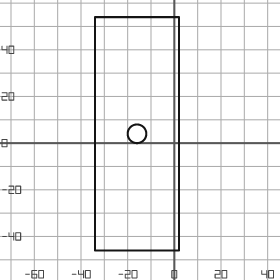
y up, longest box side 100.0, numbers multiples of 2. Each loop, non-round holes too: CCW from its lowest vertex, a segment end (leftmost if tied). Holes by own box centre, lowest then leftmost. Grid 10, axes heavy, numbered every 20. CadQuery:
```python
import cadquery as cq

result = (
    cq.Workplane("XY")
    .moveTo(-34.0, -46.0)
    .lineTo(2.0, -46.0)
    .lineTo(2.0, 54.0)
    .lineTo(-34.0, 54.0)
    .close()
    .moveTo(-16.0, 4.0)
    .circle(4.0)
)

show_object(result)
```